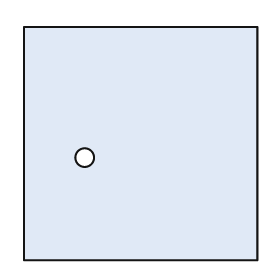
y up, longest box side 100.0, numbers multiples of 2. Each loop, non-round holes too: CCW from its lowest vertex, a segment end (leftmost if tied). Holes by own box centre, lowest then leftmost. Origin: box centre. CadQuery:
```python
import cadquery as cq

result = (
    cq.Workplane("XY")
    .moveTo(-50.0, -50.0)
    .lineTo(50.0, -50.0)
    .lineTo(50.0, 50.0)
    .lineTo(-50.0, 50.0)
    .close()
    .moveTo(-24.0, -6.0)
    .circle(4.0)
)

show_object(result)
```